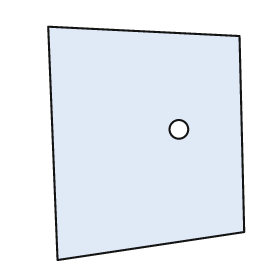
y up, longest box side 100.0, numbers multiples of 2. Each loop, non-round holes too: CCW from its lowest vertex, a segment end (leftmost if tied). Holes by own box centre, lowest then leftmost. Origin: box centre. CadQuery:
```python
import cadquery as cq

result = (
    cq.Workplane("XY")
    .moveTo(-38.0, -50.0)
    .lineTo(42.0, -38.0)
    .lineTo(40.0, 46.0)
    .lineTo(-42.0, 50.0)
    .close()
    .moveTo(14.0, 6.0)
    .circle(4.0)
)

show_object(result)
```